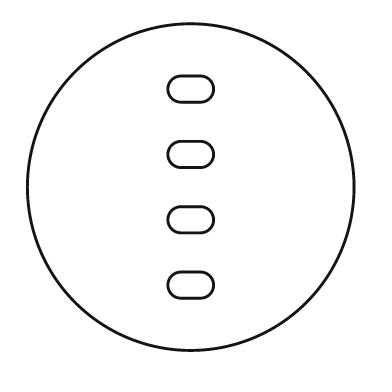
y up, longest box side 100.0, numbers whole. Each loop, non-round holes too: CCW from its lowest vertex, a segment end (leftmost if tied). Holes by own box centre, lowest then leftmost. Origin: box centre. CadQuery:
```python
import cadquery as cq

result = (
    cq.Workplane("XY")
    .moveTo(0.0, 0.0)
    .circle(50.0)
    .moveTo(-3.0, -34.0)
    .lineTo(3.0, -34.0)
    .threePointArc((7.0, -30.0), (3.0, -26.0))
    .lineTo(-3.0, -26.0)
    .threePointArc((-7.0, -30.0), (-3.0, -34.0))
    .close()
    .moveTo(-3.0, -14.0)
    .lineTo(3.0, -14.0)
    .threePointArc((7.0, -10.0), (3.0, -6.0))
    .lineTo(-3.0, -6.0)
    .threePointArc((-7.0, -10.0), (-3.0, -14.0))
    .close()
    .moveTo(-3.0, 6.0)
    .lineTo(3.0, 6.0)
    .threePointArc((7.0, 10.0), (3.0, 14.0))
    .lineTo(-3.0, 14.0)
    .threePointArc((-7.0, 10.0), (-3.0, 6.0))
    .close()
    .moveTo(-3.0, 26.0)
    .lineTo(3.0, 26.0)
    .threePointArc((7.0, 30.0), (3.0, 34.0))
    .lineTo(-3.0, 34.0)
    .threePointArc((-7.0, 30.0), (-3.0, 26.0))
    .close()
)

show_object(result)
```